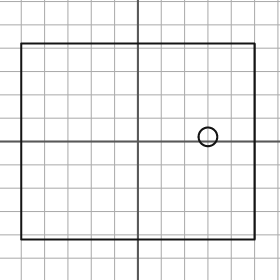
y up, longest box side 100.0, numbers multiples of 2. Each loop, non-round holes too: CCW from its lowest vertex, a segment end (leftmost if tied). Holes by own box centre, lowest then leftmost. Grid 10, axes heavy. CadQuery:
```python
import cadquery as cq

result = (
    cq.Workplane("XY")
    .moveTo(-50.0, -42.0)
    .lineTo(50.0, -42.0)
    .lineTo(50.0, 42.0)
    .lineTo(-50.0, 42.0)
    .close()
    .moveTo(30.0, 2.0)
    .circle(4.0)
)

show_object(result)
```